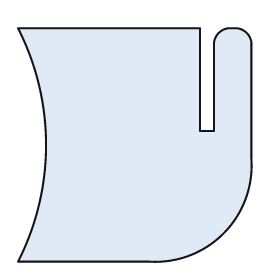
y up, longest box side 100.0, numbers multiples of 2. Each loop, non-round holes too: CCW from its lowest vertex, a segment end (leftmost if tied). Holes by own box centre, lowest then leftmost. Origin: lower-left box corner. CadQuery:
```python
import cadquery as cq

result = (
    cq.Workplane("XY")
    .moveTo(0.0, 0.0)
    .lineTo(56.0, 0.0)
    .threePointArc((88.0, 12.0), (100.0, 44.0))
    .lineTo(100.0, 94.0)
    .threePointArc((98.0, 98.0), (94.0, 100.0))
    .lineTo(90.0, 100.0)
    .threePointArc((86.0, 98.0), (84.0, 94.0))
    .lineTo(84.0, 56.0)
    .lineTo(78.0, 56.0)
    .lineTo(78.0, 100.0)
    .lineTo(0.0, 100.0)
    .threePointArc((12.0, 50.0), (0.0, 0.0))
    .close()
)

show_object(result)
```